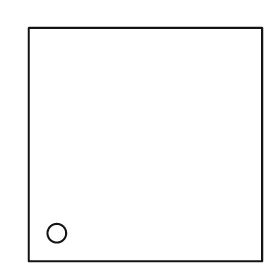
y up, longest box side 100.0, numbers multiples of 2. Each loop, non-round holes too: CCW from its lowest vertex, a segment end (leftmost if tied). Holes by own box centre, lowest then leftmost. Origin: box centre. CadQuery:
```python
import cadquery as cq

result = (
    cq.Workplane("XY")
    .moveTo(-50.0, -50.0)
    .lineTo(50.0, -50.0)
    .lineTo(50.0, 50.0)
    .lineTo(-50.0, 50.0)
    .close()
    .moveTo(-38.0, -38.0)
    .circle(4.0)
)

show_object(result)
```